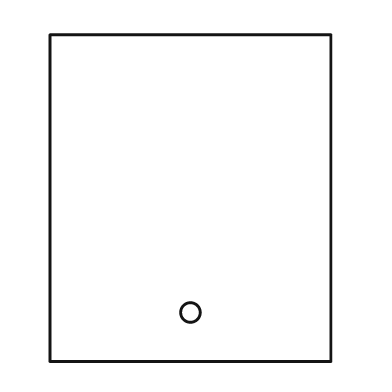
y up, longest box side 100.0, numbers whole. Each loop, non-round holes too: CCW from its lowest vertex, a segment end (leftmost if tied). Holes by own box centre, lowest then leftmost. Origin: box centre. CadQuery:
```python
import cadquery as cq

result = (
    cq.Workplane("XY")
    .moveTo(-43.0, -50.0)
    .lineTo(43.0, -50.0)
    .lineTo(43.0, 50.0)
    .lineTo(-43.0, 50.0)
    .close()
    .moveTo(0.0, -35.0)
    .circle(3.0)
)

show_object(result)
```